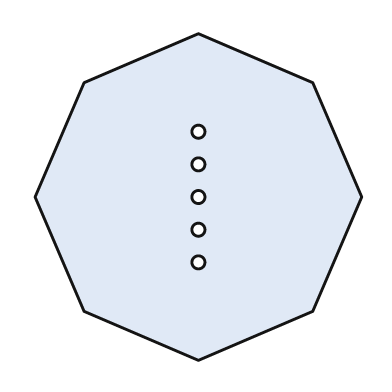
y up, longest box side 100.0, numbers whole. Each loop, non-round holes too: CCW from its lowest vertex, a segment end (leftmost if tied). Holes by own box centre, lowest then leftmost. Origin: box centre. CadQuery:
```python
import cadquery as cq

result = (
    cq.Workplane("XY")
    .moveTo(0.0, -50.0)
    .lineTo(35.0, -35.0)
    .lineTo(50.0, 0.0)
    .lineTo(35.0, 35.0)
    .lineTo(0.0, 50.0)
    .lineTo(-35.0, 35.0)
    .lineTo(-50.0, 0.0)
    .lineTo(-35.0, -35.0)
    .close()
    .moveTo(0.0, -20.0)
    .circle(2.0)
    .moveTo(0.0, -10.0)
    .circle(2.0)
    .moveTo(0.0, 0.0)
    .circle(2.0)
    .moveTo(0.0, 10.0)
    .circle(2.0)
    .moveTo(0.0, 20.0)
    .circle(2.0)
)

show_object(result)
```